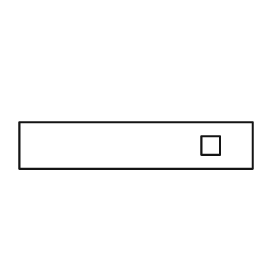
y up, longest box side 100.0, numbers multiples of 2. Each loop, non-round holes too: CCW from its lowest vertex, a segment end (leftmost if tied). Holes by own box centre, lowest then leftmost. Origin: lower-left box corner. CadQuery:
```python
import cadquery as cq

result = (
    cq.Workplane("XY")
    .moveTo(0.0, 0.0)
    .lineTo(100.0, 0.0)
    .lineTo(100.0, 20.0)
    .lineTo(0.0, 20.0)
    .close()
    .moveTo(78.0, 6.0)
    .lineTo(86.0, 6.0)
    .lineTo(86.0, 14.0)
    .lineTo(78.0, 14.0)
    .close()
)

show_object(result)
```